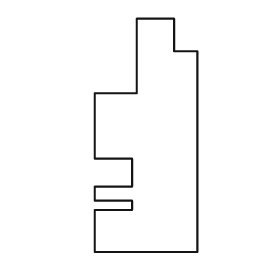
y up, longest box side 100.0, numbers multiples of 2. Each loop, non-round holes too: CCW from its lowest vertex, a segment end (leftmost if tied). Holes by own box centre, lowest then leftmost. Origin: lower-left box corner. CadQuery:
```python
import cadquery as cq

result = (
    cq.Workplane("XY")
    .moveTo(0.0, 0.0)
    .lineTo(44.0, 0.0)
    .lineTo(44.0, 86.0)
    .lineTo(34.0, 86.0)
    .lineTo(34.0, 100.0)
    .lineTo(18.0, 100.0)
    .lineTo(18.0, 68.0)
    .lineTo(0.0, 68.0)
    .lineTo(0.0, 40.0)
    .lineTo(16.0, 40.0)
    .lineTo(16.0, 28.0)
    .lineTo(0.0, 28.0)
    .lineTo(0.0, 22.0)
    .lineTo(16.0, 22.0)
    .lineTo(16.0, 18.0)
    .lineTo(0.0, 18.0)
    .close()
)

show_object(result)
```